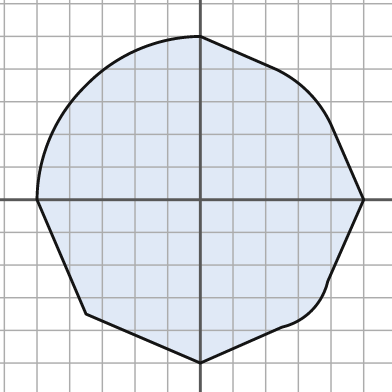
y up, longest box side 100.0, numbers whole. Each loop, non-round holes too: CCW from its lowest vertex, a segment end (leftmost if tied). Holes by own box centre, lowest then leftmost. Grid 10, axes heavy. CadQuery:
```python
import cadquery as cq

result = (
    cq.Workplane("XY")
    .moveTo(0.0, -50.0)
    .lineTo(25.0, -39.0)
    .threePointArc((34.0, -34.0), (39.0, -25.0))
    .lineTo(50.0, 0.0)
    .lineTo(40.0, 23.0)
    .threePointArc((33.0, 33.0), (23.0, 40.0))
    .lineTo(0.0, 50.0)
    .threePointArc((-19.0, 46.0), (-35.0, 35.0))
    .threePointArc((-46.0, 19.0), (-50.0, 0.0))
    .lineTo(-35.0, -35.0)
    .close()
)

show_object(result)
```